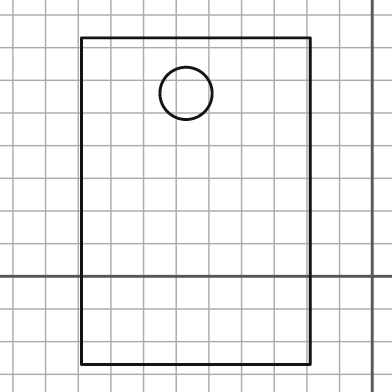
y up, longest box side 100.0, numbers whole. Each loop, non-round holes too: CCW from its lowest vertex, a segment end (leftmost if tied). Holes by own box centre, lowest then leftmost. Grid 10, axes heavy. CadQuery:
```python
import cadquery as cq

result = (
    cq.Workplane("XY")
    .moveTo(-89.0, -27.0)
    .lineTo(-19.0, -27.0)
    .lineTo(-19.0, 73.0)
    .lineTo(-89.0, 73.0)
    .close()
    .moveTo(-57.0, 56.0)
    .circle(8.0)
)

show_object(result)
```